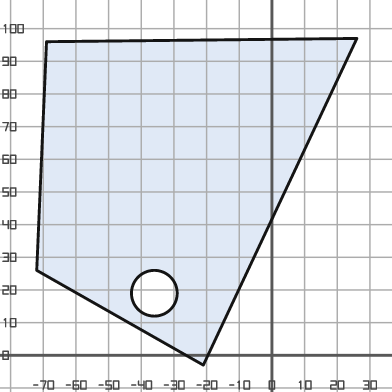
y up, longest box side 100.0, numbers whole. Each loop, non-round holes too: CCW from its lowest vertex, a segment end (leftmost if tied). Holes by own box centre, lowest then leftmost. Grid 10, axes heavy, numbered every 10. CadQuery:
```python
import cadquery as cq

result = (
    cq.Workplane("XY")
    .moveTo(-21.0, -3.0)
    .lineTo(26.0, 97.0)
    .lineTo(-69.0, 96.0)
    .lineTo(-72.0, 26.0)
    .close()
    .moveTo(-36.0, 19.0)
    .circle(7.0)
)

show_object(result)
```